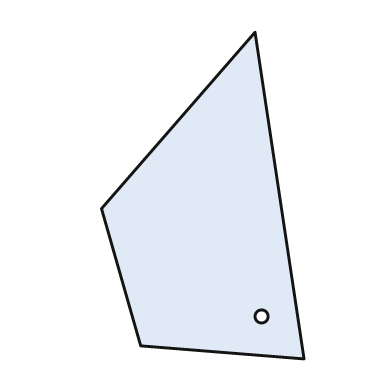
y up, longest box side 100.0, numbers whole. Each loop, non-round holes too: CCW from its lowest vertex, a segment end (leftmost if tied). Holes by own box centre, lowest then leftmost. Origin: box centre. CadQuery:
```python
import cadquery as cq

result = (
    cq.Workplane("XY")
    .moveTo(31.0, -50.0)
    .lineTo(16.0, 50.0)
    .lineTo(-31.0, -4.0)
    .lineTo(-19.0, -46.0)
    .close()
    .moveTo(18.0, -37.0)
    .circle(2.0)
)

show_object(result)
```